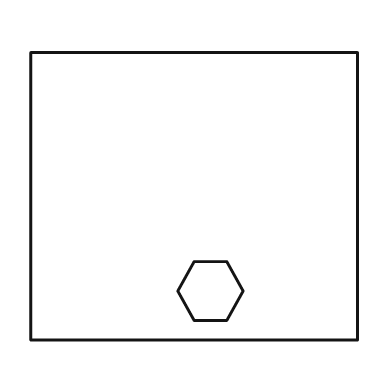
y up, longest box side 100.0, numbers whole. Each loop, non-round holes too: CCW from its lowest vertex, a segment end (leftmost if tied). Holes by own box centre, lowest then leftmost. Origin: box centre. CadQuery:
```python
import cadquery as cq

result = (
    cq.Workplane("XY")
    .moveTo(-50.0, -44.0)
    .lineTo(50.0, -44.0)
    .lineTo(50.0, 44.0)
    .lineTo(-50.0, 44.0)
    .close()
    .moveTo(0.0, -38.0)
    .lineTo(10.0, -38.0)
    .lineTo(15.0, -29.0)
    .lineTo(10.0, -20.0)
    .lineTo(0.0, -20.0)
    .lineTo(-5.0, -29.0)
    .close()
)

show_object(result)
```